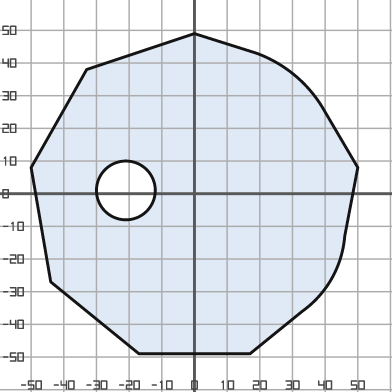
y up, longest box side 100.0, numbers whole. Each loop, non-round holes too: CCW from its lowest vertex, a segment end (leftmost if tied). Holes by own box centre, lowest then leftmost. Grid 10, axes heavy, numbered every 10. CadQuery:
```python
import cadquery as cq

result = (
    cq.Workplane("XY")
    .moveTo(-17.0, -49.0)
    .lineTo(17.0, -49.0)
    .lineTo(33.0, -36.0)
    .threePointArc((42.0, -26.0), (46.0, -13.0))
    .lineTo(50.0, 8.0)
    .lineTo(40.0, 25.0)
    .threePointArc((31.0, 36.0), (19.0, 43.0))
    .lineTo(0.0, 49.0)
    .lineTo(-33.0, 38.0)
    .lineTo(-50.0, 8.0)
    .lineTo(-44.0, -27.0)
    .close()
    .moveTo(-21.0, 1.0)
    .circle(9.0)
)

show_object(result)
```